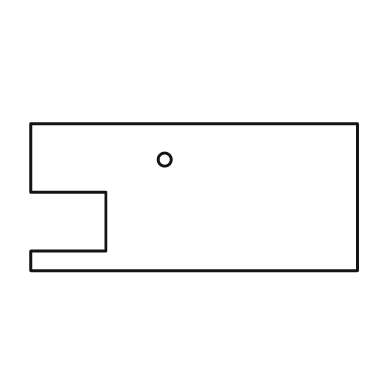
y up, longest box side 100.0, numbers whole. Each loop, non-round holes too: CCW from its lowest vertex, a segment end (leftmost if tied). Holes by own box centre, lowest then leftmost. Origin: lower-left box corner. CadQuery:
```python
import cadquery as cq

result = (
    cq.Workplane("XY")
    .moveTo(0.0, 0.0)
    .lineTo(100.0, 0.0)
    .lineTo(100.0, 45.0)
    .lineTo(0.0, 45.0)
    .lineTo(0.0, 24.0)
    .lineTo(23.0, 24.0)
    .lineTo(23.0, 6.0)
    .lineTo(0.0, 6.0)
    .close()
    .moveTo(41.0, 34.0)
    .circle(2.0)
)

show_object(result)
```